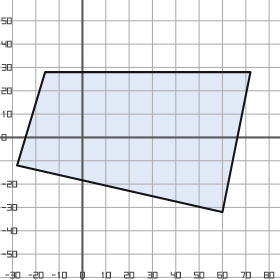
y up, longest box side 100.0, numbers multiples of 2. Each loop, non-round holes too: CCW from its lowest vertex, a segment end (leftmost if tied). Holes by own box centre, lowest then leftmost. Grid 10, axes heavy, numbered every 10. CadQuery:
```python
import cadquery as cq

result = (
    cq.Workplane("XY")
    .moveTo(60.0, -32.0)
    .lineTo(72.0, 28.0)
    .lineTo(-16.0, 28.0)
    .lineTo(-28.0, -12.0)
    .close()
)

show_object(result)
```